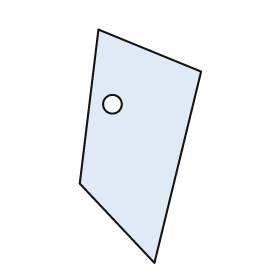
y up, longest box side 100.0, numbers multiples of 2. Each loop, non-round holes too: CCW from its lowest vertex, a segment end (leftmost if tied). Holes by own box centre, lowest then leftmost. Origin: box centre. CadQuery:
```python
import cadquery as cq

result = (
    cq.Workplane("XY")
    .moveTo(6.0, -50.0)
    .lineTo(26.0, 32.0)
    .lineTo(-18.0, 50.0)
    .lineTo(-26.0, -16.0)
    .close()
    .moveTo(-12.0, 18.0)
    .circle(4.0)
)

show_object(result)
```